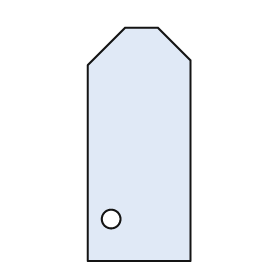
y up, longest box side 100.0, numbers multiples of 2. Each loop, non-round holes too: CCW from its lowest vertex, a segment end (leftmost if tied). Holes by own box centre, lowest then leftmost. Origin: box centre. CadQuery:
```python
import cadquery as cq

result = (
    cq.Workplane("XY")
    .moveTo(-22.0, -50.0)
    .lineTo(22.0, -50.0)
    .lineTo(22.0, 36.0)
    .lineTo(8.0, 50.0)
    .lineTo(-6.0, 50.0)
    .lineTo(-22.0, 34.0)
    .close()
    .moveTo(-12.0, -32.0)
    .circle(4.0)
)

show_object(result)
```